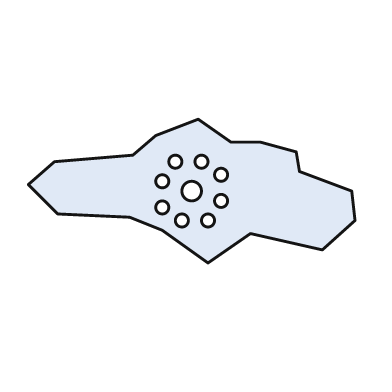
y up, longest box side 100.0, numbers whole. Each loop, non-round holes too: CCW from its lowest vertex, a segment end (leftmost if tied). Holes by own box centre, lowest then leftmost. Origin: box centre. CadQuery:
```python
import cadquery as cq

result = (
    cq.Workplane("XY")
    .moveTo(5.0, -22.0)
    .lineTo(18.0, -13.0)
    .lineTo(40.0, -18.0)
    .lineTo(50.0, -9.0)
    .lineTo(49.0, 0.0)
    .lineTo(33.0, 6.0)
    .lineTo(32.0, 12.0)
    .lineTo(21.0, 15.0)
    .lineTo(12.0, 15.0)
    .lineTo(2.0, 22.0)
    .lineTo(-11.0, 17.0)
    .lineTo(-18.0, 11.0)
    .lineTo(-42.0, 9.0)
    .lineTo(-50.0, 2.0)
    .lineTo(-41.0, -7.0)
    .lineTo(-19.0, -8.0)
    .lineTo(-9.0, -12.0)
    .close()
    .moveTo(-3.0, -9.0)
    .circle(2.0)
    .moveTo(5.0, -9.0)
    .circle(2.0)
    .moveTo(-9.0, -5.0)
    .circle(2.0)
    .moveTo(9.0, -3.0)
    .circle(2.0)
    .moveTo(0.0, 0.0)
    .circle(3.0)
    .moveTo(-9.0, 3.0)
    .circle(2.0)
    .moveTo(9.0, 5.0)
    .circle(2.0)
    .moveTo(-5.0, 9.0)
    .circle(2.0)
    .moveTo(3.0, 9.0)
    .circle(2.0)
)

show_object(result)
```